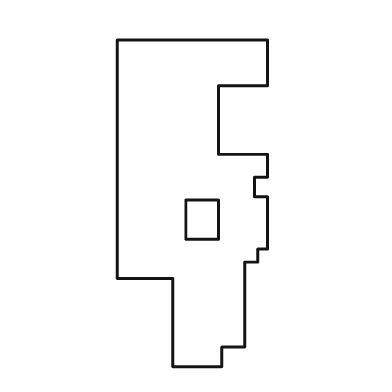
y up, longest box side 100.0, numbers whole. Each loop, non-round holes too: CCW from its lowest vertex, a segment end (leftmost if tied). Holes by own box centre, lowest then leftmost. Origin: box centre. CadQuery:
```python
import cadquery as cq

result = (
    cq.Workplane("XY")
    .moveTo(-6.0, -50.0)
    .lineTo(9.0, -50.0)
    .lineTo(9.0, -44.0)
    .lineTo(16.0, -44.0)
    .lineTo(16.0, -18.0)
    .lineTo(20.0, -18.0)
    .lineTo(20.0, -14.0)
    .lineTo(23.0, -14.0)
    .lineTo(23.0, 2.0)
    .lineTo(19.0, 2.0)
    .lineTo(19.0, 8.0)
    .lineTo(23.0, 8.0)
    .lineTo(23.0, 15.0)
    .lineTo(8.0, 15.0)
    .lineTo(8.0, 36.0)
    .lineTo(23.0, 36.0)
    .lineTo(23.0, 50.0)
    .lineTo(-23.0, 50.0)
    .lineTo(-23.0, -23.0)
    .lineTo(-6.0, -23.0)
    .close()
    .moveTo(-2.0, -11.0)
    .lineTo(8.0, -11.0)
    .lineTo(8.0, 1.0)
    .lineTo(-2.0, 1.0)
    .close()
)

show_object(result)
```